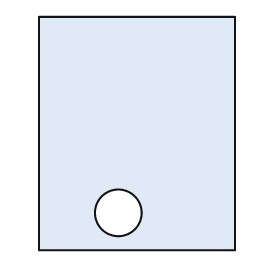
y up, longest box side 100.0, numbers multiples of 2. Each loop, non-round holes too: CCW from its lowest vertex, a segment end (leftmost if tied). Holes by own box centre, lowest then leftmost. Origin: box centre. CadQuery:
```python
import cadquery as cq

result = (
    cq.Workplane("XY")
    .moveTo(-42.0, -50.0)
    .lineTo(42.0, -50.0)
    .lineTo(42.0, 50.0)
    .lineTo(-42.0, 50.0)
    .close()
    .moveTo(-8.0, -34.0)
    .circle(10.0)
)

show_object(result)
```